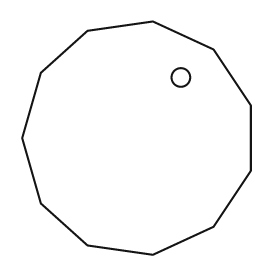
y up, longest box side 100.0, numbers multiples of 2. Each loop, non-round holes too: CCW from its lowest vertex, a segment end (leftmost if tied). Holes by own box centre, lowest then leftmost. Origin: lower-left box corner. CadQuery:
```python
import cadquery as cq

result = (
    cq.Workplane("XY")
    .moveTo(56.0, 0.0)
    .lineTo(82.0, 12.0)
    .lineTo(98.0, 36.0)
    .lineTo(98.0, 64.0)
    .lineTo(82.0, 88.0)
    .lineTo(56.0, 100.0)
    .lineTo(28.0, 96.0)
    .lineTo(8.0, 78.0)
    .lineTo(0.0, 50.0)
    .lineTo(8.0, 22.0)
    .lineTo(28.0, 4.0)
    .close()
    .moveTo(68.0, 76.0)
    .circle(4.0)
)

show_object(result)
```